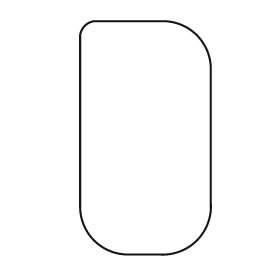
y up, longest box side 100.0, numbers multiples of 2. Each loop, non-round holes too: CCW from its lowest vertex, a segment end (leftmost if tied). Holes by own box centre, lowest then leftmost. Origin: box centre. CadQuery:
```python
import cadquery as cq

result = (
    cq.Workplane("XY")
    .moveTo(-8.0, -50.0)
    .lineTo(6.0, -50.0)
    .threePointArc((22.0, -44.0), (28.0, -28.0))
    .lineTo(28.0, 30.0)
    .threePointArc((22.0, 44.0), (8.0, 50.0))
    .lineTo(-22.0, 50.0)
    .threePointArc((-26.0, 48.0), (-28.0, 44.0))
    .lineTo(-28.0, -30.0)
    .threePointArc((-22.0, -44.0), (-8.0, -50.0))
    .close()
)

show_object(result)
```